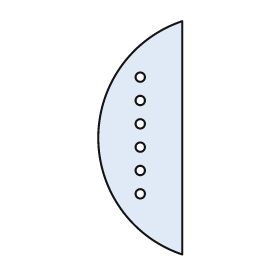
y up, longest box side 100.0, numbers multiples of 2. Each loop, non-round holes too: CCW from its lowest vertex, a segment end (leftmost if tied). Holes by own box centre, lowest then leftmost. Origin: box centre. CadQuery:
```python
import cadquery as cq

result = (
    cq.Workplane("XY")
    .moveTo(18.0, -50.0)
    .lineTo(18.0, 50.0)
    .threePointArc((-18.0, 0.0), (18.0, -50.0))
    .close()
    .moveTo(0.0, -24.0)
    .circle(2.0)
    .moveTo(0.0, -14.0)
    .circle(2.0)
    .moveTo(0.0, -4.0)
    .circle(2.0)
    .moveTo(0.0, 6.0)
    .circle(2.0)
    .moveTo(0.0, 16.0)
    .circle(2.0)
    .moveTo(0.0, 26.0)
    .circle(2.0)
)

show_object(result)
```